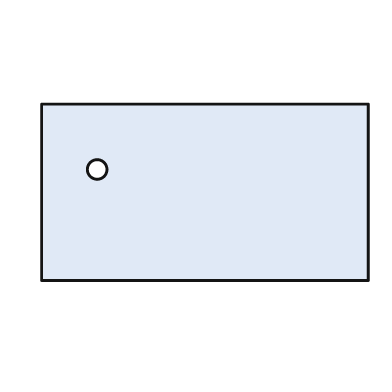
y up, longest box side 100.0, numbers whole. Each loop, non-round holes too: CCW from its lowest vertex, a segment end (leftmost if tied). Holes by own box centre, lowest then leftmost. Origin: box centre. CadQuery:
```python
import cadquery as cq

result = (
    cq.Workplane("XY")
    .moveTo(-50.0, -27.0)
    .lineTo(50.0, -27.0)
    .lineTo(50.0, 27.0)
    .lineTo(-50.0, 27.0)
    .close()
    .moveTo(-33.0, 7.0)
    .circle(3.0)
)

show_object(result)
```